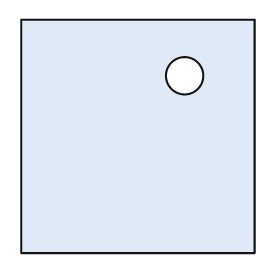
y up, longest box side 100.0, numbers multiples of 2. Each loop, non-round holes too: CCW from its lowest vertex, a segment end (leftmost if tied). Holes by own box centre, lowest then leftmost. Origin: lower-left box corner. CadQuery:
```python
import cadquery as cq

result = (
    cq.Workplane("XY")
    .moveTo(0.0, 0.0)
    .lineTo(100.0, 0.0)
    .lineTo(100.0, 100.0)
    .lineTo(0.0, 100.0)
    .close()
    .moveTo(70.0, 76.0)
    .circle(8.0)
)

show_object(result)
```